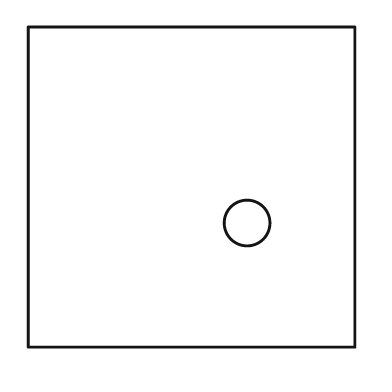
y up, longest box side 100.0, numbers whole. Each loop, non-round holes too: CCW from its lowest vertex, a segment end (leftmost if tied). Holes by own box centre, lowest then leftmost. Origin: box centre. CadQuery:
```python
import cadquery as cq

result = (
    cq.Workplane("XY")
    .moveTo(-50.0, -49.0)
    .lineTo(50.0, -49.0)
    .lineTo(50.0, 49.0)
    .lineTo(-50.0, 49.0)
    .close()
    .moveTo(17.0, -11.0)
    .circle(7.0)
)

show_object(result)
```